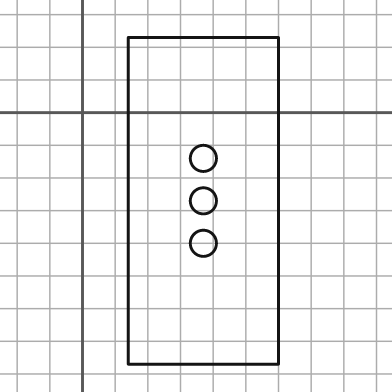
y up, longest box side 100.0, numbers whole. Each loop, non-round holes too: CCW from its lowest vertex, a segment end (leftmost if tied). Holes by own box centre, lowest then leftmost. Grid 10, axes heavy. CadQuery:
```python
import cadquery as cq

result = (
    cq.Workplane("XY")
    .moveTo(14.0, -77.0)
    .lineTo(60.0, -77.0)
    .lineTo(60.0, 23.0)
    .lineTo(14.0, 23.0)
    .close()
    .moveTo(37.0, -40.0)
    .circle(4.0)
    .moveTo(37.0, -27.0)
    .circle(4.0)
    .moveTo(37.0, -14.0)
    .circle(4.0)
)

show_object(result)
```